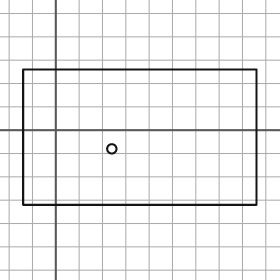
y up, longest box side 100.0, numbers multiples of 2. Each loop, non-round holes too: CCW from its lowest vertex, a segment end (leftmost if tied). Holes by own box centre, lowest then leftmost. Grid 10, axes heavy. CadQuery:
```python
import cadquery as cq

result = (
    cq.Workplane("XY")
    .moveTo(-14.0, -32.0)
    .lineTo(86.0, -32.0)
    .lineTo(86.0, 26.0)
    .lineTo(-14.0, 26.0)
    .close()
    .moveTo(24.0, -8.0)
    .circle(2.0)
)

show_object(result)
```